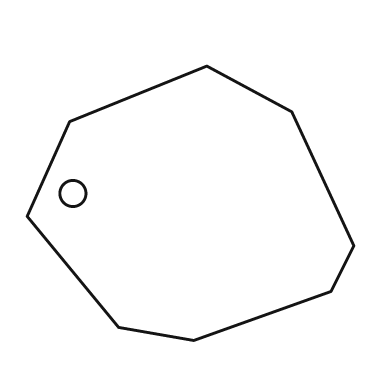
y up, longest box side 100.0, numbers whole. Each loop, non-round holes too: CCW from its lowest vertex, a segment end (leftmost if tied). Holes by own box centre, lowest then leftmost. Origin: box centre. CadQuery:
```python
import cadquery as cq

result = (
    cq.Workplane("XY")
    .moveTo(1.0, -42.0)
    .lineTo(43.0, -27.0)
    .lineTo(50.0, -13.0)
    .lineTo(31.0, 28.0)
    .lineTo(5.0, 42.0)
    .lineTo(-37.0, 25.0)
    .lineTo(-50.0, -4.0)
    .lineTo(-22.0, -38.0)
    .close()
    .moveTo(-36.0, 3.0)
    .circle(4.0)
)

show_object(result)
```